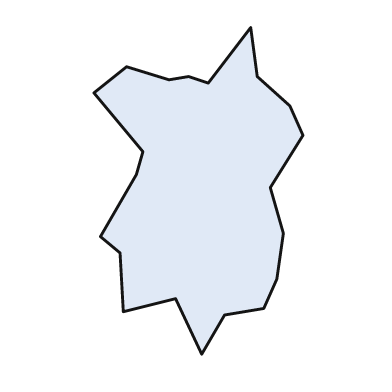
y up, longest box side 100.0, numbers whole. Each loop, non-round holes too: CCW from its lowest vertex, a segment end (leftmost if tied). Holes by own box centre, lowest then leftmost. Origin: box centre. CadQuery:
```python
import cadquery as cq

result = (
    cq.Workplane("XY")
    .moveTo(1.0, -50.0)
    .lineTo(8.0, -38.0)
    .lineTo(20.0, -36.0)
    .lineTo(24.0, -27.0)
    .lineTo(26.0, -13.0)
    .lineTo(22.0, 1.0)
    .lineTo(32.0, 17.0)
    .lineTo(28.0, 26.0)
    .lineTo(18.0, 35.0)
    .lineTo(16.0, 50.0)
    .lineTo(3.0, 33.0)
    .lineTo(-3.0, 35.0)
    .lineTo(-9.0, 34.0)
    .lineTo(-22.0, 38.0)
    .lineTo(-32.0, 30.0)
    .lineTo(-17.0, 12.0)
    .lineTo(-19.0, 5.0)
    .lineTo(-30.0, -14.0)
    .lineTo(-24.0, -19.0)
    .lineTo(-23.0, -37.0)
    .lineTo(-7.0, -33.0)
    .close()
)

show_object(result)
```